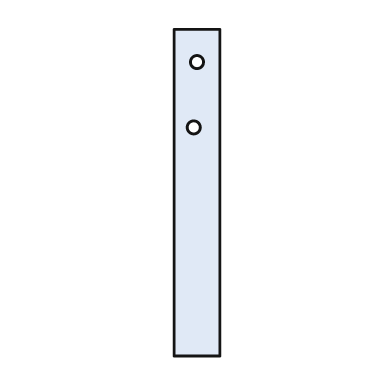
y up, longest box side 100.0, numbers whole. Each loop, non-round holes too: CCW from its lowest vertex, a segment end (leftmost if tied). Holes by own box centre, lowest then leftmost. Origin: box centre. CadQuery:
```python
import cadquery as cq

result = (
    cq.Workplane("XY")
    .moveTo(-7.0, -50.0)
    .lineTo(7.0, -50.0)
    .lineTo(7.0, 50.0)
    .lineTo(-7.0, 50.0)
    .close()
    .moveTo(-1.0, 20.0)
    .circle(2.0)
    .moveTo(0.0, 40.0)
    .circle(2.0)
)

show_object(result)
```